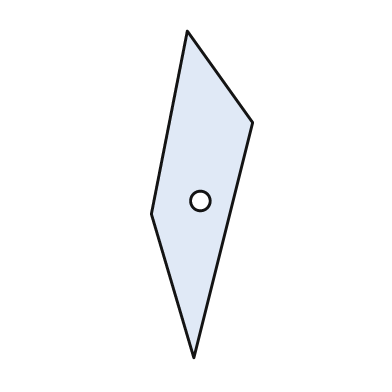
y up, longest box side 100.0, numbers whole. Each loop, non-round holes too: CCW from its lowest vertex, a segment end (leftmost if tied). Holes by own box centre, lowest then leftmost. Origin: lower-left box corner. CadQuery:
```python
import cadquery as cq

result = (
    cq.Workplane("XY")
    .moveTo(13.0, 0.0)
    .lineTo(31.0, 72.0)
    .lineTo(11.0, 100.0)
    .lineTo(0.0, 44.0)
    .close()
    .moveTo(15.0, 48.0)
    .circle(3.0)
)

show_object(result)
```